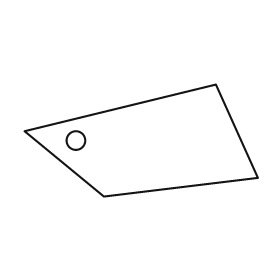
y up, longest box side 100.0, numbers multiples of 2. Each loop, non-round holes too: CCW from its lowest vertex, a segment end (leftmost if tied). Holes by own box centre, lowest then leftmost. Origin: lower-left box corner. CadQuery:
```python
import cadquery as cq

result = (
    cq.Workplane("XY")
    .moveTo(34.0, 0.0)
    .lineTo(100.0, 8.0)
    .lineTo(82.0, 48.0)
    .lineTo(0.0, 28.0)
    .close()
    .moveTo(22.0, 24.0)
    .circle(4.0)
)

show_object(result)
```